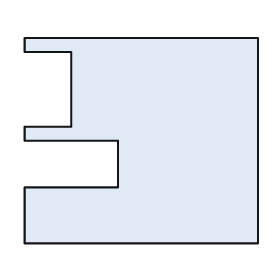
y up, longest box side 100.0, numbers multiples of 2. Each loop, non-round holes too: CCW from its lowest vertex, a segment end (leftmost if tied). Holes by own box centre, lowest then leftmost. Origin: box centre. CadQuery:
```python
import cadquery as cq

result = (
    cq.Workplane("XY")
    .moveTo(-50.0, -44.0)
    .lineTo(50.0, -44.0)
    .lineTo(50.0, 44.0)
    .lineTo(-50.0, 44.0)
    .lineTo(-50.0, 38.0)
    .lineTo(-30.0, 38.0)
    .lineTo(-30.0, 6.0)
    .lineTo(-50.0, 6.0)
    .lineTo(-50.0, 0.0)
    .lineTo(-10.0, 0.0)
    .lineTo(-10.0, -20.0)
    .lineTo(-50.0, -20.0)
    .close()
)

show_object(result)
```